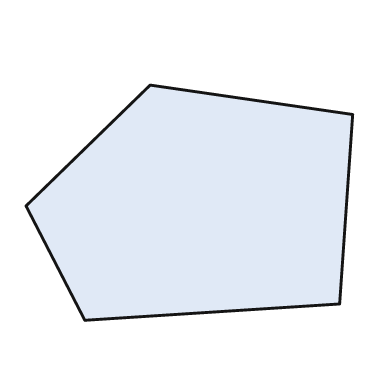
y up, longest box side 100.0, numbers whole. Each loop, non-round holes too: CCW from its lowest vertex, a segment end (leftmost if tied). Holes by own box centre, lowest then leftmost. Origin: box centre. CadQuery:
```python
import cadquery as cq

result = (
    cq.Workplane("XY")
    .moveTo(-32.0, -36.0)
    .lineTo(46.0, -31.0)
    .lineTo(50.0, 27.0)
    .lineTo(-12.0, 36.0)
    .lineTo(-50.0, -1.0)
    .close()
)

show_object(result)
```